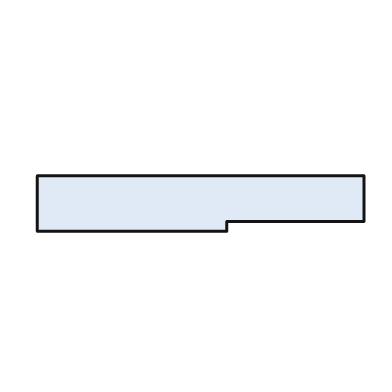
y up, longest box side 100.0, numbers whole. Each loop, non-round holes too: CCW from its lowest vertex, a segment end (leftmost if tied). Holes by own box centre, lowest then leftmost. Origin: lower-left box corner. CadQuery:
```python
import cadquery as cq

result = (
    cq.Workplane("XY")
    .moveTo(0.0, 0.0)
    .lineTo(58.0, 0.0)
    .lineTo(58.0, 3.0)
    .lineTo(100.0, 3.0)
    .lineTo(100.0, 17.0)
    .lineTo(0.0, 17.0)
    .close()
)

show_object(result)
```